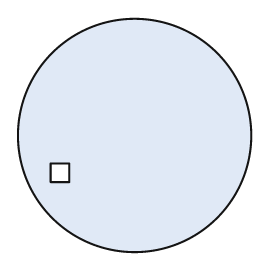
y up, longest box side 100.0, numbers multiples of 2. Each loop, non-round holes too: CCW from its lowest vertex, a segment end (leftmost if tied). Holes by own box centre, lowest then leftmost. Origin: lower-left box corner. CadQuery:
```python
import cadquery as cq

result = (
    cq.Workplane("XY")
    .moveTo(50.0, 50.0)
    .circle(50.0)
    .moveTo(14.0, 30.0)
    .lineTo(22.0, 30.0)
    .lineTo(22.0, 38.0)
    .lineTo(14.0, 38.0)
    .close()
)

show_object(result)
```